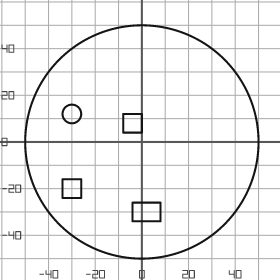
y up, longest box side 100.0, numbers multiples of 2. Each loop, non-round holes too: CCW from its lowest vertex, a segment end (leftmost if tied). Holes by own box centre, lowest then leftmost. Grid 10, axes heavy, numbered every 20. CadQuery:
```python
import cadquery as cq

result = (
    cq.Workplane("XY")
    .moveTo(0.0, 0.0)
    .circle(50.0)
    .moveTo(-4.0, -34.0)
    .lineTo(8.0, -34.0)
    .lineTo(8.0, -26.0)
    .lineTo(-4.0, -26.0)
    .close()
    .moveTo(-34.0, -24.0)
    .lineTo(-26.0, -24.0)
    .lineTo(-26.0, -16.0)
    .lineTo(-34.0, -16.0)
    .close()
    .moveTo(-8.0, 4.0)
    .lineTo(0.0, 4.0)
    .lineTo(0.0, 12.0)
    .lineTo(-8.0, 12.0)
    .close()
    .moveTo(-30.0, 12.0)
    .circle(4.0)
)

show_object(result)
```